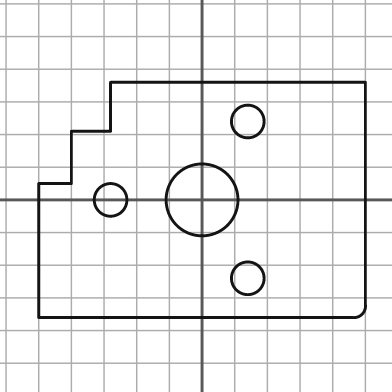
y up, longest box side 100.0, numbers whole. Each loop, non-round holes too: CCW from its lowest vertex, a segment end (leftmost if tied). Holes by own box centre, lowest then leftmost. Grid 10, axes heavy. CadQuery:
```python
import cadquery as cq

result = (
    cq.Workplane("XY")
    .moveTo(-50.0, -36.0)
    .lineTo(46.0, -36.0)
    .threePointArc((49.0, -35.0), (50.0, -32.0))
    .lineTo(50.0, 36.0)
    .lineTo(-28.0, 36.0)
    .lineTo(-28.0, 21.0)
    .lineTo(-40.0, 21.0)
    .lineTo(-40.0, 5.0)
    .lineTo(-50.0, 5.0)
    .close()
    .moveTo(14.0, -24.0)
    .circle(5.0)
    .moveTo(-28.0, 0.0)
    .circle(5.0)
    .moveTo(0.0, 0.0)
    .circle(11.0)
    .moveTo(14.0, 24.0)
    .circle(5.0)
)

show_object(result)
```